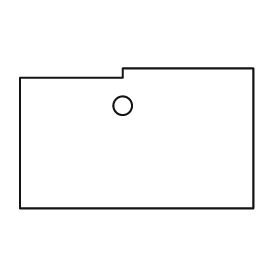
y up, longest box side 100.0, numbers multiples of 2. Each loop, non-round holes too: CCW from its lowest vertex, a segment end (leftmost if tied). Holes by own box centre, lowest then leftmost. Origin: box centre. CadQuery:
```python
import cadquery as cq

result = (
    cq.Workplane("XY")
    .moveTo(-50.0, -30.0)
    .lineTo(50.0, -30.0)
    .lineTo(50.0, 30.0)
    .lineTo(-6.0, 30.0)
    .lineTo(-6.0, 26.0)
    .lineTo(-50.0, 26.0)
    .close()
    .moveTo(-6.0, 14.0)
    .circle(4.0)
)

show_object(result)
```